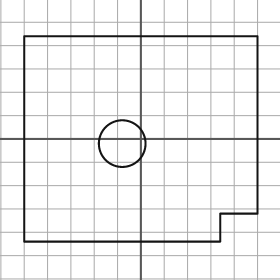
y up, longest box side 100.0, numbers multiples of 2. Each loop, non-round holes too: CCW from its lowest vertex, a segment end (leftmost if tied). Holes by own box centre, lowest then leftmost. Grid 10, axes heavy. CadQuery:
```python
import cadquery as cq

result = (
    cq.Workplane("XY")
    .moveTo(-50.0, -44.0)
    .lineTo(34.0, -44.0)
    .lineTo(34.0, -32.0)
    .lineTo(50.0, -32.0)
    .lineTo(50.0, 44.0)
    .lineTo(-50.0, 44.0)
    .close()
    .moveTo(-8.0, -2.0)
    .circle(10.0)
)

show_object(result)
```